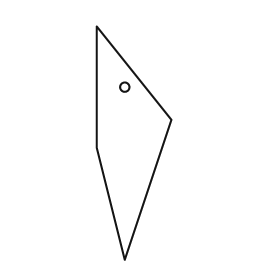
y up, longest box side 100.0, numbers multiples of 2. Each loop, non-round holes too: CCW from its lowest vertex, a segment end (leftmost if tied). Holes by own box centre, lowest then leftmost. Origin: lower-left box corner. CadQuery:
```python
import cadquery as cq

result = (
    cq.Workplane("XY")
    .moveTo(12.0, 0.0)
    .lineTo(32.0, 60.0)
    .lineTo(0.0, 100.0)
    .lineTo(0.0, 48.0)
    .close()
    .moveTo(12.0, 74.0)
    .circle(2.0)
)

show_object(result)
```